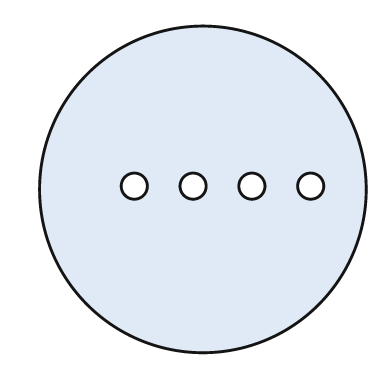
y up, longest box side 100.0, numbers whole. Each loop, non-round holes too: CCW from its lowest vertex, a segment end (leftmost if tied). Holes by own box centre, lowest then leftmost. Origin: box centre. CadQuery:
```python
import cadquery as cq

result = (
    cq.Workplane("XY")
    .moveTo(0.0, 0.0)
    .circle(50.0)
    .moveTo(-21.0, 1.0)
    .circle(4.0)
    .moveTo(-3.0, 1.0)
    .circle(4.0)
    .moveTo(15.0, 1.0)
    .circle(4.0)
    .moveTo(33.0, 1.0)
    .circle(4.0)
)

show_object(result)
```